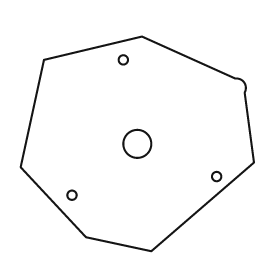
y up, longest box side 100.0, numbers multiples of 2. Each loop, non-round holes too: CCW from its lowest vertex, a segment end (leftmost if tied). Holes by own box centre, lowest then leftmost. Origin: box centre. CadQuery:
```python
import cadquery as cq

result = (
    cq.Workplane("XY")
    .moveTo(6.0, -46.0)
    .lineTo(50.0, -8.0)
    .lineTo(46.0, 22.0)
    .threePointArc((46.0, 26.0), (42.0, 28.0))
    .lineTo(2.0, 46.0)
    .lineTo(-40.0, 36.0)
    .lineTo(-50.0, -10.0)
    .lineTo(-22.0, -40.0)
    .close()
    .moveTo(-28.0, -22.0)
    .circle(2.0)
    .moveTo(34.0, -14.0)
    .circle(2.0)
    .moveTo(0.0, 0.0)
    .circle(6.0)
    .moveTo(-6.0, 36.0)
    .circle(2.0)
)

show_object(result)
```